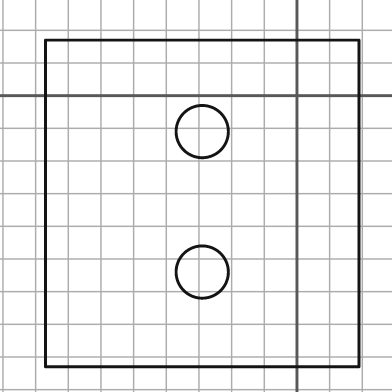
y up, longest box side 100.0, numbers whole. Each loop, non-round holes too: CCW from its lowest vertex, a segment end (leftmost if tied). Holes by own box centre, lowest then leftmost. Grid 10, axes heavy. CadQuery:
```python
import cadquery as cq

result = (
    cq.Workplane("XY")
    .moveTo(-77.0, -83.0)
    .lineTo(19.0, -83.0)
    .lineTo(19.0, 17.0)
    .lineTo(-77.0, 17.0)
    .close()
    .moveTo(-29.0, -54.0)
    .circle(8.0)
    .moveTo(-29.0, -11.0)
    .circle(8.0)
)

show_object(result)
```